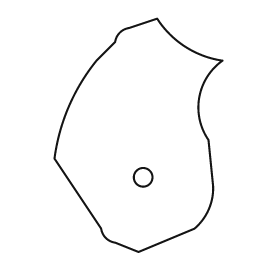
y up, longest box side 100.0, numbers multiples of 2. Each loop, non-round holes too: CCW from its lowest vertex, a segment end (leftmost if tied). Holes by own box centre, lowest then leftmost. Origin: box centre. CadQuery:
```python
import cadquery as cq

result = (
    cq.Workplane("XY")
    .moveTo(0.0, -50.0)
    .lineTo(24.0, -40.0)
    .threePointArc((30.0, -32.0), (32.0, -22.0))
    .lineTo(30.0, -2.0)
    .threePointArc((26.0, 16.0), (36.0, 32.0))
    .threePointArc((20.0, 38.0), (8.0, 50.0))
    .lineTo(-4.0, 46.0)
    .threePointArc((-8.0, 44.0), (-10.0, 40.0))
    .lineTo(-18.0, 32.0)
    .threePointArc((-30.0, 12.0), (-36.0, -10.0))
    .lineTo(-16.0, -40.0)
    .threePointArc((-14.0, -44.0), (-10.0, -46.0))
    .close()
    .moveTo(2.0, -18.0)
    .circle(4.0)
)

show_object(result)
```